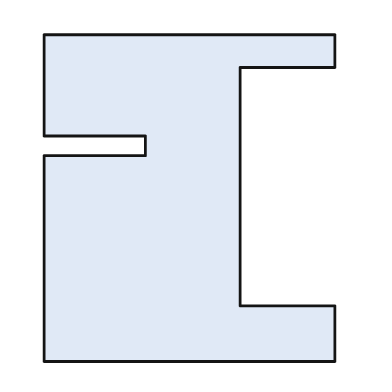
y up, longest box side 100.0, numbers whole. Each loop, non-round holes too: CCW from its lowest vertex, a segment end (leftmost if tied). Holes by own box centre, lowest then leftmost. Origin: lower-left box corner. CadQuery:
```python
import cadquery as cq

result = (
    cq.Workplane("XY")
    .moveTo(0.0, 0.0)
    .lineTo(89.0, 0.0)
    .lineTo(89.0, 17.0)
    .lineTo(60.0, 17.0)
    .lineTo(60.0, 90.0)
    .lineTo(89.0, 90.0)
    .lineTo(89.0, 100.0)
    .lineTo(0.0, 100.0)
    .lineTo(0.0, 69.0)
    .lineTo(31.0, 69.0)
    .lineTo(31.0, 63.0)
    .lineTo(0.0, 63.0)
    .close()
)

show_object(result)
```